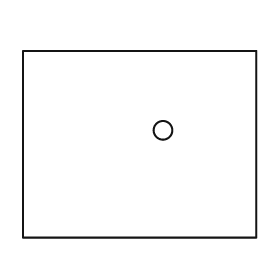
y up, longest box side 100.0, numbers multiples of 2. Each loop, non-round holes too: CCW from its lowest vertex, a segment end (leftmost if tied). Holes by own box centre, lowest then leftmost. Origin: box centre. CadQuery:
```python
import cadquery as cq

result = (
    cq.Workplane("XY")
    .moveTo(-50.0, -40.0)
    .lineTo(50.0, -40.0)
    .lineTo(50.0, 40.0)
    .lineTo(-50.0, 40.0)
    .close()
    .moveTo(10.0, 6.0)
    .circle(4.0)
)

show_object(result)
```